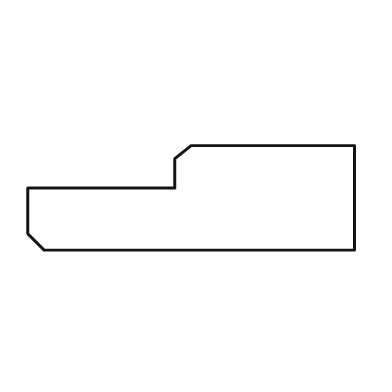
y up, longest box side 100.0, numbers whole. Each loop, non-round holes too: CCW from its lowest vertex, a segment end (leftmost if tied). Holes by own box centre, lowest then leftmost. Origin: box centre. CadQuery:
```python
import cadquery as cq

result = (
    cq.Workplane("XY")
    .moveTo(-45.0, -16.0)
    .lineTo(50.0, -16.0)
    .lineTo(50.0, 16.0)
    .lineTo(0.0, 16.0)
    .lineTo(-5.0, 12.0)
    .lineTo(-5.0, 3.0)
    .lineTo(-50.0, 3.0)
    .lineTo(-50.0, -11.0)
    .close()
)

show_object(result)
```